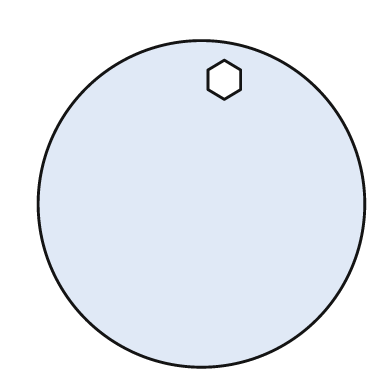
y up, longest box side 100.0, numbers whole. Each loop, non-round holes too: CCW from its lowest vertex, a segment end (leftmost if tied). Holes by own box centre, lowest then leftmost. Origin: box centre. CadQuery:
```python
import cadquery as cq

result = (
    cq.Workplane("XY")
    .moveTo(0.0, 0.0)
    .circle(50.0)
    .moveTo(7.0, 32.0)
    .lineTo(12.0, 35.0)
    .lineTo(12.0, 41.0)
    .lineTo(7.0, 44.0)
    .lineTo(2.0, 41.0)
    .lineTo(2.0, 35.0)
    .close()
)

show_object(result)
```